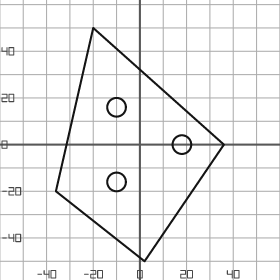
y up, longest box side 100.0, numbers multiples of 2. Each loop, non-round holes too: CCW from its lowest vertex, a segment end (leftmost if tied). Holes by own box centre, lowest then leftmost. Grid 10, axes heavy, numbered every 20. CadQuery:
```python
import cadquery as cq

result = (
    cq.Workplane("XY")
    .moveTo(2.0, -50.0)
    .lineTo(36.0, 0.0)
    .lineTo(-20.0, 50.0)
    .lineTo(-36.0, -20.0)
    .close()
    .moveTo(-10.0, -16.0)
    .circle(4.0)
    .moveTo(18.0, 0.0)
    .circle(4.0)
    .moveTo(-10.0, 16.0)
    .circle(4.0)
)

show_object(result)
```